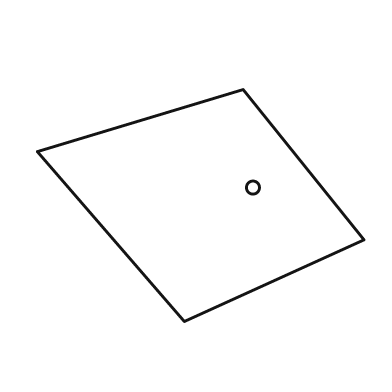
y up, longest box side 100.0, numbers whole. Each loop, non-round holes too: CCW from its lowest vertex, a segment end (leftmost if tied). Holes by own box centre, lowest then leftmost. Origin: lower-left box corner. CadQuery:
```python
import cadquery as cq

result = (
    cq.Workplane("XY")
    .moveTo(45.0, 0.0)
    .lineTo(100.0, 25.0)
    .lineTo(63.0, 71.0)
    .lineTo(0.0, 52.0)
    .close()
    .moveTo(66.0, 41.0)
    .circle(2.0)
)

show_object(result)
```